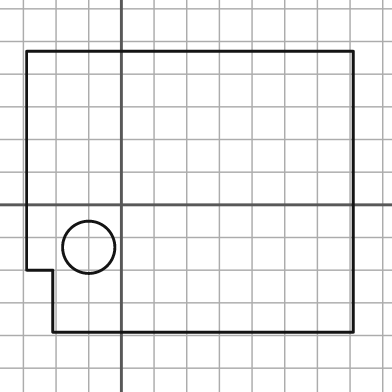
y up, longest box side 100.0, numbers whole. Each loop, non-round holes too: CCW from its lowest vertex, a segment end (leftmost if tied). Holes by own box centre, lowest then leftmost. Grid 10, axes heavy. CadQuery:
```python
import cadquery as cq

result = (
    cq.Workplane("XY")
    .moveTo(-21.0, -39.0)
    .lineTo(71.0, -39.0)
    .lineTo(71.0, 47.0)
    .lineTo(-29.0, 47.0)
    .lineTo(-29.0, -20.0)
    .lineTo(-21.0, -20.0)
    .close()
    .moveTo(-10.0, -13.0)
    .circle(8.0)
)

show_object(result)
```